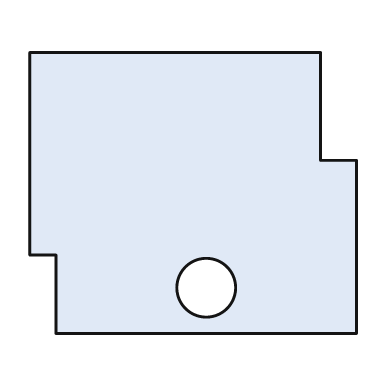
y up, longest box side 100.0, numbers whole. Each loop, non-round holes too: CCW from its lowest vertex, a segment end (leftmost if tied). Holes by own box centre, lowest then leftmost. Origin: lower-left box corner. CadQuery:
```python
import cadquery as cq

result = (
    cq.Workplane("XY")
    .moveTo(8.0, 0.0)
    .lineTo(100.0, 0.0)
    .lineTo(100.0, 53.0)
    .lineTo(89.0, 53.0)
    .lineTo(89.0, 86.0)
    .lineTo(0.0, 86.0)
    .lineTo(0.0, 24.0)
    .lineTo(8.0, 24.0)
    .close()
    .moveTo(54.0, 14.0)
    .circle(9.0)
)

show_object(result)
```